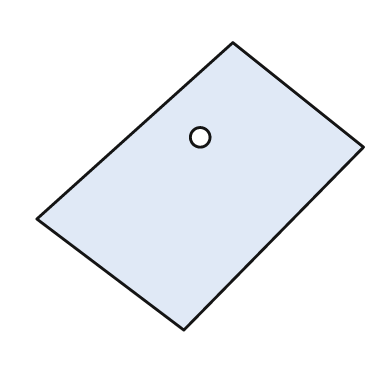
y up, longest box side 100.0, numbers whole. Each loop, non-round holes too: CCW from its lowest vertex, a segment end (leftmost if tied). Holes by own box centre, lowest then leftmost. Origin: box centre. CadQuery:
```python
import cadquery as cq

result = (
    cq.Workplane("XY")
    .moveTo(-5.0, -44.0)
    .lineTo(50.0, 12.0)
    .lineTo(10.0, 44.0)
    .lineTo(-50.0, -10.0)
    .close()
    .moveTo(0.0, 15.0)
    .circle(3.0)
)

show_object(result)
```